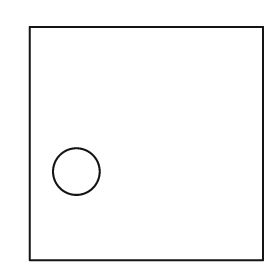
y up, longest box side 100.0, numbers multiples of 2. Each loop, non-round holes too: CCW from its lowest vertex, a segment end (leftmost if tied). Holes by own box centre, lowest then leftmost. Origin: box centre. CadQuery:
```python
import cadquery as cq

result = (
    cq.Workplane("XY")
    .moveTo(-50.0, -50.0)
    .lineTo(50.0, -50.0)
    .lineTo(50.0, 50.0)
    .lineTo(-50.0, 50.0)
    .close()
    .moveTo(-30.0, -12.0)
    .circle(10.0)
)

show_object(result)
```